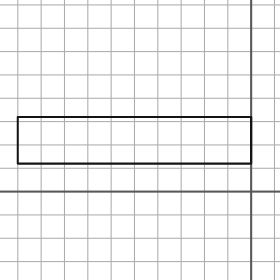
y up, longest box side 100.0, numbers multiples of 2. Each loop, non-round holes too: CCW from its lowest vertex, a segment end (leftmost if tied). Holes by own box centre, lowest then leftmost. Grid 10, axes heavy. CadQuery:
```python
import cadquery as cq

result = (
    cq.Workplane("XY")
    .moveTo(-100.0, 12.0)
    .lineTo(0.0, 12.0)
    .lineTo(0.0, 32.0)
    .lineTo(-100.0, 32.0)
    .close()
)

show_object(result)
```